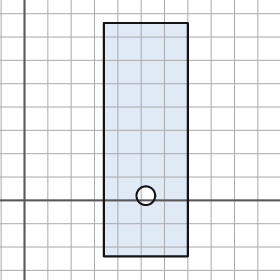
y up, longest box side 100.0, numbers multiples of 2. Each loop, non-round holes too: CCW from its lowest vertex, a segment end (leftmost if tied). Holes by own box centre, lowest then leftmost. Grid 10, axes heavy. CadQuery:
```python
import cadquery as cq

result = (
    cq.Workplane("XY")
    .moveTo(34.0, -24.0)
    .lineTo(70.0, -24.0)
    .lineTo(70.0, 76.0)
    .lineTo(34.0, 76.0)
    .close()
    .moveTo(52.0, 2.0)
    .circle(4.0)
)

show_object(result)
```